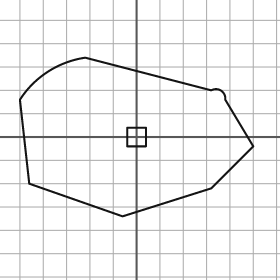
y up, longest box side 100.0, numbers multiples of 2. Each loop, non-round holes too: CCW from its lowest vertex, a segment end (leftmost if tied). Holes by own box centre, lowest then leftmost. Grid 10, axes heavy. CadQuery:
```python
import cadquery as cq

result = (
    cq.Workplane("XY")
    .moveTo(-6.0, -34.0)
    .lineTo(32.0, -22.0)
    .lineTo(50.0, -4.0)
    .lineTo(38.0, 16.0)
    .threePointArc((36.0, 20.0), (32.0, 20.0))
    .lineTo(-22.0, 34.0)
    .threePointArc((-38.0, 28.0), (-50.0, 16.0))
    .lineTo(-46.0, -20.0)
    .close()
    .moveTo(-4.0, -4.0)
    .lineTo(4.0, -4.0)
    .lineTo(4.0, 4.0)
    .lineTo(-4.0, 4.0)
    .close()
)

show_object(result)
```